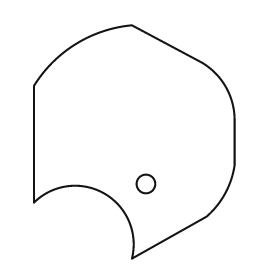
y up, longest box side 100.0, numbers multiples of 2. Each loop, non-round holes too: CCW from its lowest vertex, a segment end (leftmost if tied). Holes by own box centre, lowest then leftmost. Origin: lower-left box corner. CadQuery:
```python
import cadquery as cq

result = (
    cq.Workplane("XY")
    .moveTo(42.0, 0.0)
    .lineTo(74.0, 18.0)
    .threePointArc((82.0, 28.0), (86.0, 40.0))
    .lineTo(86.0, 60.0)
    .threePointArc((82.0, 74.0), (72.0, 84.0))
    .lineTo(42.0, 100.0)
    .threePointArc((18.0, 92.0), (0.0, 74.0))
    .lineTo(0.0, 24.0)
    .threePointArc((30.0, 28.0), (42.0, 0.0))
    .close()
    .moveTo(48.0, 32.0)
    .circle(4.0)
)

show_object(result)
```